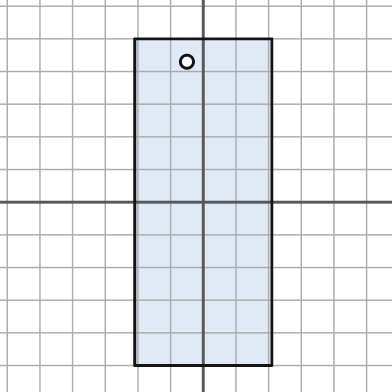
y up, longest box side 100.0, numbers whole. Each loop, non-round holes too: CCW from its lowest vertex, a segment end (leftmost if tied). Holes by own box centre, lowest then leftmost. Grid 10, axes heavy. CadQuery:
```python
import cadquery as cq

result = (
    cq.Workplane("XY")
    .moveTo(-21.0, -50.0)
    .lineTo(21.0, -50.0)
    .lineTo(21.0, 50.0)
    .lineTo(-21.0, 50.0)
    .close()
    .moveTo(-5.0, 43.0)
    .circle(2.0)
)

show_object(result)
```